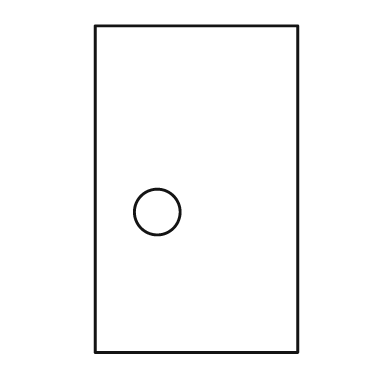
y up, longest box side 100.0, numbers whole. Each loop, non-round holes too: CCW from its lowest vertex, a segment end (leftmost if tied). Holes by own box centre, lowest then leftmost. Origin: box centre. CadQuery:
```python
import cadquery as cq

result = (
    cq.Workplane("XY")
    .moveTo(-31.0, -50.0)
    .lineTo(31.0, -50.0)
    .lineTo(31.0, 50.0)
    .lineTo(-31.0, 50.0)
    .close()
    .moveTo(-12.0, -7.0)
    .circle(7.0)
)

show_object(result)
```